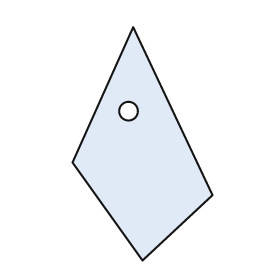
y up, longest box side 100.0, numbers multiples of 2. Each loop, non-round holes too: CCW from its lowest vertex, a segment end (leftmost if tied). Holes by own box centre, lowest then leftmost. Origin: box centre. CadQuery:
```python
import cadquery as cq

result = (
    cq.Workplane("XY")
    .moveTo(0.0, -50.0)
    .lineTo(30.0, -22.0)
    .lineTo(-4.0, 50.0)
    .lineTo(-30.0, -8.0)
    .close()
    .moveTo(-6.0, 14.0)
    .circle(4.0)
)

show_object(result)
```